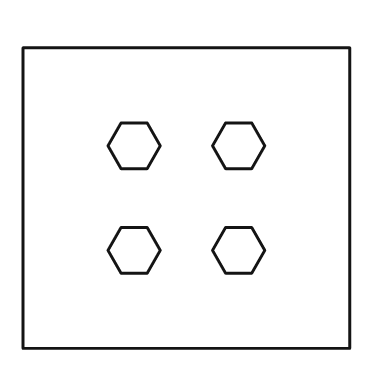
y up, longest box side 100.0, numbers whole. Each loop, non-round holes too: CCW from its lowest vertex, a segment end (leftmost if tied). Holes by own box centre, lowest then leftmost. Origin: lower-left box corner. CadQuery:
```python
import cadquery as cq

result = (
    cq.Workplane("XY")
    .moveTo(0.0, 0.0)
    .lineTo(100.0, 0.0)
    .lineTo(100.0, 92.0)
    .lineTo(0.0, 92.0)
    .close()
    .moveTo(30.0, 23.0)
    .lineTo(38.0, 23.0)
    .lineTo(42.0, 30.0)
    .lineTo(38.0, 37.0)
    .lineTo(30.0, 37.0)
    .lineTo(26.0, 30.0)
    .close()
    .moveTo(62.0, 23.0)
    .lineTo(70.0, 23.0)
    .lineTo(74.0, 30.0)
    .lineTo(70.0, 37.0)
    .lineTo(62.0, 37.0)
    .lineTo(58.0, 30.0)
    .close()
    .moveTo(30.0, 55.0)
    .lineTo(38.0, 55.0)
    .lineTo(42.0, 62.0)
    .lineTo(38.0, 69.0)
    .lineTo(30.0, 69.0)
    .lineTo(26.0, 62.0)
    .close()
    .moveTo(62.0, 55.0)
    .lineTo(70.0, 55.0)
    .lineTo(74.0, 62.0)
    .lineTo(70.0, 69.0)
    .lineTo(62.0, 69.0)
    .lineTo(58.0, 62.0)
    .close()
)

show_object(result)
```